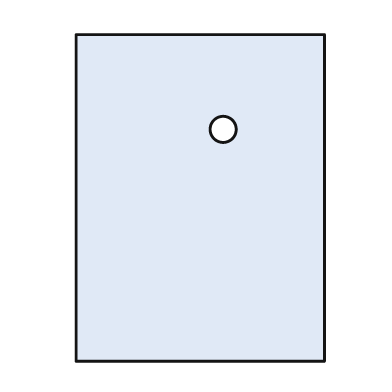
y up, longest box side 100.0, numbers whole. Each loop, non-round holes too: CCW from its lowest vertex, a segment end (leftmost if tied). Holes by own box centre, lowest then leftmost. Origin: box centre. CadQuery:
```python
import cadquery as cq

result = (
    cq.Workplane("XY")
    .moveTo(-38.0, -50.0)
    .lineTo(38.0, -50.0)
    .lineTo(38.0, 50.0)
    .lineTo(-38.0, 50.0)
    .close()
    .moveTo(7.0, 21.0)
    .circle(4.0)
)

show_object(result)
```